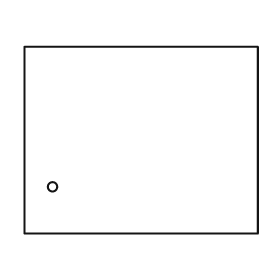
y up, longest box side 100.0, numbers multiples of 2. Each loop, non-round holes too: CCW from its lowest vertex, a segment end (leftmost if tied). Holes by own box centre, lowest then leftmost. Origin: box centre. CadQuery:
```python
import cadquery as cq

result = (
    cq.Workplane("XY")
    .moveTo(-50.0, -40.0)
    .lineTo(50.0, -40.0)
    .lineTo(50.0, 40.0)
    .lineTo(-50.0, 40.0)
    .close()
    .moveTo(-38.0, -20.0)
    .circle(2.0)
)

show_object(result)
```